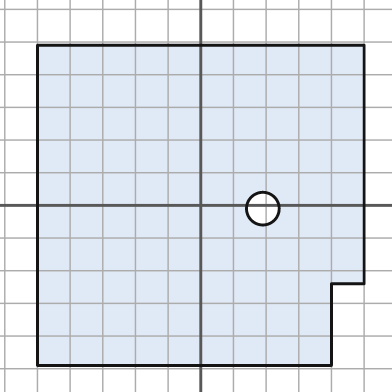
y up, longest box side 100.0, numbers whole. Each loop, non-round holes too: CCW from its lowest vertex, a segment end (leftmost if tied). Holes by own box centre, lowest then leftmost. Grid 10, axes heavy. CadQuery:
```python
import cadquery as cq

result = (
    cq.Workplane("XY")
    .moveTo(-50.0, -49.0)
    .lineTo(40.0, -49.0)
    .lineTo(40.0, -24.0)
    .lineTo(50.0, -24.0)
    .lineTo(50.0, 49.0)
    .lineTo(-50.0, 49.0)
    .close()
    .moveTo(19.0, -1.0)
    .circle(5.0)
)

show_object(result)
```